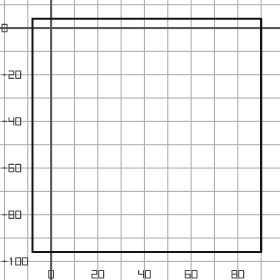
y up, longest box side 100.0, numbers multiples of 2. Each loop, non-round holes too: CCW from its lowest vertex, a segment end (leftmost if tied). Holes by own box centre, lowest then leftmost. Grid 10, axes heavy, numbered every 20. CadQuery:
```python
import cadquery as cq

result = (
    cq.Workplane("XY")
    .moveTo(-8.0, -96.0)
    .lineTo(90.0, -96.0)
    .lineTo(90.0, 4.0)
    .lineTo(-8.0, 4.0)
    .close()
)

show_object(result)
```